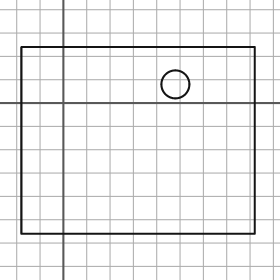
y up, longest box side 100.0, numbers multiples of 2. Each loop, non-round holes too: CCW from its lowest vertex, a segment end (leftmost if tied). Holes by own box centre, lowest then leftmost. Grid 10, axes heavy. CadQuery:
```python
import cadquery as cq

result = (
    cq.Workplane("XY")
    .moveTo(-18.0, -56.0)
    .lineTo(82.0, -56.0)
    .lineTo(82.0, 24.0)
    .lineTo(-18.0, 24.0)
    .close()
    .moveTo(48.0, 8.0)
    .circle(6.0)
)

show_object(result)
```